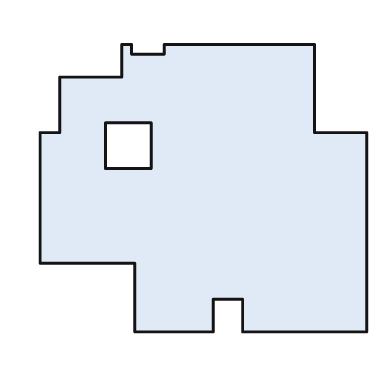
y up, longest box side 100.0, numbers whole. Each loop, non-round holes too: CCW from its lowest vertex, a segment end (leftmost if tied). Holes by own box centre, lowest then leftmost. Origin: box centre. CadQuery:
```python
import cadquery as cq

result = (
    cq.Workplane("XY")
    .moveTo(-21.0, -44.0)
    .lineTo(3.0, -44.0)
    .lineTo(3.0, -34.0)
    .lineTo(12.0, -34.0)
    .lineTo(12.0, -44.0)
    .lineTo(50.0, -44.0)
    .lineTo(50.0, 17.0)
    .lineTo(34.0, 17.0)
    .lineTo(34.0, 44.0)
    .lineTo(-12.0, 44.0)
    .lineTo(-12.0, 41.0)
    .lineTo(-22.0, 41.0)
    .lineTo(-22.0, 44.0)
    .lineTo(-25.0, 44.0)
    .lineTo(-25.0, 34.0)
    .lineTo(-44.0, 34.0)
    .lineTo(-44.0, 17.0)
    .lineTo(-50.0, 17.0)
    .lineTo(-50.0, -23.0)
    .lineTo(-21.0, -23.0)
    .close()
    .moveTo(-30.0, 6.0)
    .lineTo(-16.0, 6.0)
    .lineTo(-16.0, 20.0)
    .lineTo(-30.0, 20.0)
    .close()
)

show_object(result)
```